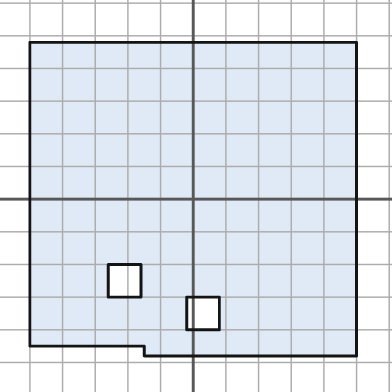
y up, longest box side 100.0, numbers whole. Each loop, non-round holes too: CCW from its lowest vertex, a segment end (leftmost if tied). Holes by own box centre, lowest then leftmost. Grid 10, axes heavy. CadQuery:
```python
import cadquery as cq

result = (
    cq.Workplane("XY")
    .moveTo(-15.0, -48.0)
    .lineTo(50.0, -48.0)
    .lineTo(50.0, 48.0)
    .lineTo(-50.0, 48.0)
    .lineTo(-50.0, -45.0)
    .lineTo(-15.0, -45.0)
    .close()
    .moveTo(-2.0, -40.0)
    .lineTo(8.0, -40.0)
    .lineTo(8.0, -30.0)
    .lineTo(-2.0, -30.0)
    .close()
    .moveTo(-26.0, -30.0)
    .lineTo(-16.0, -30.0)
    .lineTo(-16.0, -20.0)
    .lineTo(-26.0, -20.0)
    .close()
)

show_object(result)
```